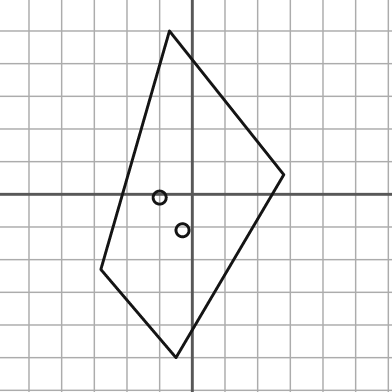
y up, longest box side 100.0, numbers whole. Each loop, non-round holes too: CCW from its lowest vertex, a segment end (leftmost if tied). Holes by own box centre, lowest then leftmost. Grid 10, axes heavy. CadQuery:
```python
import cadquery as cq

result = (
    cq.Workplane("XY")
    .moveTo(-5.0, -50.0)
    .lineTo(28.0, 6.0)
    .lineTo(-7.0, 50.0)
    .lineTo(-28.0, -23.0)
    .close()
    .moveTo(-3.0, -11.0)
    .circle(2.0)
    .moveTo(-10.0, -1.0)
    .circle(2.0)
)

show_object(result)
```